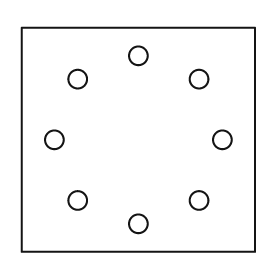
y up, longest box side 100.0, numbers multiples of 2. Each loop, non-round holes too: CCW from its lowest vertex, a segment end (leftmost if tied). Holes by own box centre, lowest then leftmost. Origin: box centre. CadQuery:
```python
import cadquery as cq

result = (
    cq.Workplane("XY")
    .moveTo(-50.0, -48.0)
    .lineTo(50.0, -48.0)
    .lineTo(50.0, 48.0)
    .lineTo(-50.0, 48.0)
    .close()
    .moveTo(0.0, -36.0)
    .circle(4.0)
    .moveTo(-26.0, -26.0)
    .circle(4.0)
    .moveTo(26.0, -26.0)
    .circle(4.0)
    .moveTo(-36.0, 0.0)
    .circle(4.0)
    .moveTo(36.0, 0.0)
    .circle(4.0)
    .moveTo(-26.0, 26.0)
    .circle(4.0)
    .moveTo(26.0, 26.0)
    .circle(4.0)
    .moveTo(0.0, 36.0)
    .circle(4.0)
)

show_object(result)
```